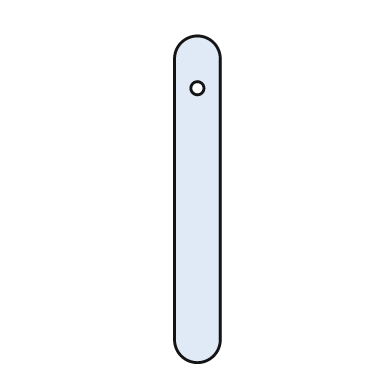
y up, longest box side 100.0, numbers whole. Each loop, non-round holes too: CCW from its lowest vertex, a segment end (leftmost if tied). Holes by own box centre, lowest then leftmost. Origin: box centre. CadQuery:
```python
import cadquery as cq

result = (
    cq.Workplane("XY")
    .moveTo(-7.0, -43.0)
    .threePointArc((0.0, -50.0), (7.0, -43.0))
    .lineTo(7.0, 43.0)
    .threePointArc((0.0, 50.0), (-7.0, 43.0))
    .close()
    .moveTo(0.0, 34.0)
    .circle(2.0)
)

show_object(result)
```